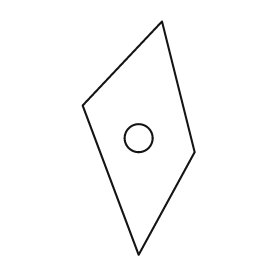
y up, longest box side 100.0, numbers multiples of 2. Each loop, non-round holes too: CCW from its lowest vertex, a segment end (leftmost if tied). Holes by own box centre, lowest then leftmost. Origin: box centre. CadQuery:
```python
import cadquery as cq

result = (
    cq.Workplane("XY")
    .moveTo(0.0, -50.0)
    .lineTo(24.0, -6.0)
    .lineTo(10.0, 50.0)
    .lineTo(-24.0, 14.0)
    .close()
    .moveTo(0.0, 0.0)
    .circle(6.0)
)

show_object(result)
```